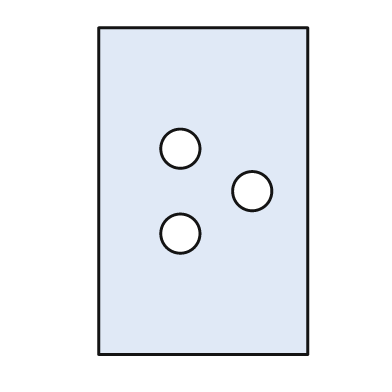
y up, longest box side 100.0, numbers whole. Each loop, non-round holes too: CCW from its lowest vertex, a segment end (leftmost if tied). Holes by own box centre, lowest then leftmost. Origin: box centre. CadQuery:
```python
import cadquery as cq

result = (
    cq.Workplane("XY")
    .moveTo(-32.0, -50.0)
    .lineTo(32.0, -50.0)
    .lineTo(32.0, 50.0)
    .lineTo(-32.0, 50.0)
    .close()
    .moveTo(-7.0, -13.0)
    .circle(6.0)
    .moveTo(15.0, 0.0)
    .circle(6.0)
    .moveTo(-7.0, 13.0)
    .circle(6.0)
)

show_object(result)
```